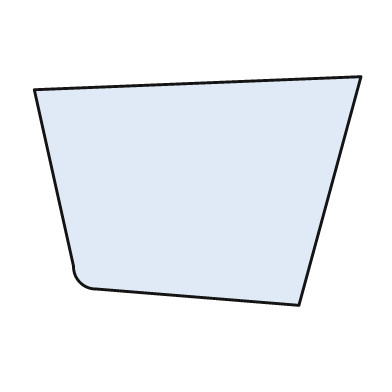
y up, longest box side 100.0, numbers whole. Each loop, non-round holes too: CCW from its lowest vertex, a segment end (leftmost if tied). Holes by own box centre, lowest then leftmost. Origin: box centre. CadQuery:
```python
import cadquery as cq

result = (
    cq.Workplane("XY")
    .moveTo(31.0, -35.0)
    .lineTo(50.0, 35.0)
    .lineTo(-50.0, 31.0)
    .lineTo(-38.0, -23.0)
    .threePointArc((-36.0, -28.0), (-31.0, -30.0))
    .close()
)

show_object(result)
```